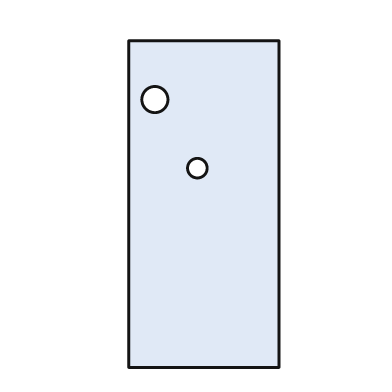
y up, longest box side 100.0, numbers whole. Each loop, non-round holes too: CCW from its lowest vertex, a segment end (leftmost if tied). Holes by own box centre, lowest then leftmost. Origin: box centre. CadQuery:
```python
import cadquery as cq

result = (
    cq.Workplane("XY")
    .moveTo(-23.0, -50.0)
    .lineTo(23.0, -50.0)
    .lineTo(23.0, 50.0)
    .lineTo(-23.0, 50.0)
    .close()
    .moveTo(-2.0, 11.0)
    .circle(3.0)
    .moveTo(-15.0, 32.0)
    .circle(4.0)
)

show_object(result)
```